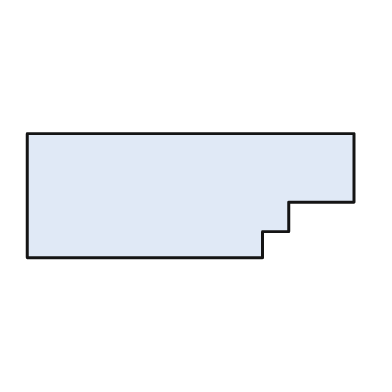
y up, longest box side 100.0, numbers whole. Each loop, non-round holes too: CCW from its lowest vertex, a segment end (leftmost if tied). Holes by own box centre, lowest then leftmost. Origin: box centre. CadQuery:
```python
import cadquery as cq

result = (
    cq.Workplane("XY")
    .moveTo(-50.0, -19.0)
    .lineTo(22.0, -19.0)
    .lineTo(22.0, -11.0)
    .lineTo(30.0, -11.0)
    .lineTo(30.0, -2.0)
    .lineTo(50.0, -2.0)
    .lineTo(50.0, 19.0)
    .lineTo(-50.0, 19.0)
    .close()
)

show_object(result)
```